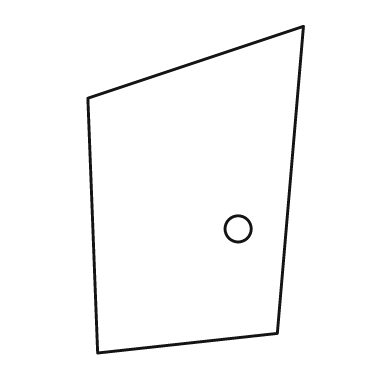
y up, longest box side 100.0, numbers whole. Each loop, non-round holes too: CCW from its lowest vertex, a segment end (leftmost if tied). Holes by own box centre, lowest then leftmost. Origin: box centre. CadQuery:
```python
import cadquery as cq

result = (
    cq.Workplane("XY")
    .moveTo(-30.0, -50.0)
    .lineTo(25.0, -44.0)
    .lineTo(33.0, 50.0)
    .lineTo(-33.0, 28.0)
    .close()
    .moveTo(13.0, -12.0)
    .circle(4.0)
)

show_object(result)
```